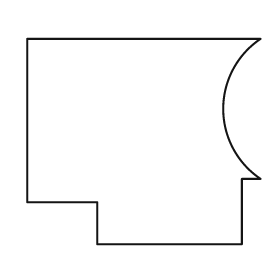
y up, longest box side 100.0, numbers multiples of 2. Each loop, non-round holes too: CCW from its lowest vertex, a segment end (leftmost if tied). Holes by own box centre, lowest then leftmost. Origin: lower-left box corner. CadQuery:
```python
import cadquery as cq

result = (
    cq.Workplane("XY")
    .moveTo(30.0, 0.0)
    .lineTo(92.0, 0.0)
    .lineTo(92.0, 28.0)
    .lineTo(100.0, 28.0)
    .threePointArc((84.0, 58.0), (100.0, 88.0))
    .lineTo(0.0, 88.0)
    .lineTo(0.0, 18.0)
    .lineTo(30.0, 18.0)
    .close()
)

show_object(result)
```